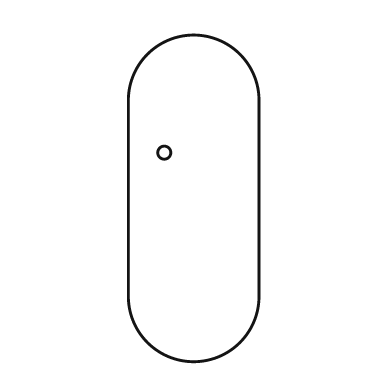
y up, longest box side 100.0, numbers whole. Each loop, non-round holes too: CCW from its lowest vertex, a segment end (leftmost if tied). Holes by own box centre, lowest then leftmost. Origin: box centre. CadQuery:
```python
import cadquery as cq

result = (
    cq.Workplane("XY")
    .moveTo(-20.0, -30.0)
    .threePointArc((0.0, -50.0), (20.0, -30.0))
    .lineTo(20.0, 30.0)
    .threePointArc((0.0, 50.0), (-20.0, 30.0))
    .close()
    .moveTo(-9.0, 14.0)
    .circle(2.0)
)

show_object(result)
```